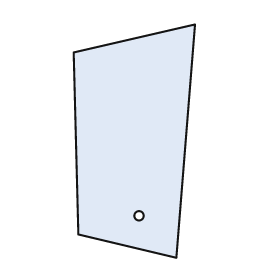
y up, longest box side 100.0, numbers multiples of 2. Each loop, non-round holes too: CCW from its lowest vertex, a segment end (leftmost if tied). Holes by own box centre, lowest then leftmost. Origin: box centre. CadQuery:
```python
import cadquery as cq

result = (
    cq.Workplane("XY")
    .moveTo(18.0, -50.0)
    .lineTo(26.0, 50.0)
    .lineTo(-26.0, 38.0)
    .lineTo(-24.0, -40.0)
    .close()
    .moveTo(2.0, -32.0)
    .circle(2.0)
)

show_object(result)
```